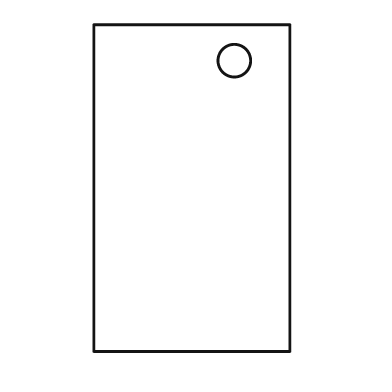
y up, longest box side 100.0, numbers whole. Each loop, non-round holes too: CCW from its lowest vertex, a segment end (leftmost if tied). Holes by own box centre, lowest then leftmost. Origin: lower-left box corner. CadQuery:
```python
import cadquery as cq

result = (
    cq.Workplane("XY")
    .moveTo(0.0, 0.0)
    .lineTo(60.0, 0.0)
    .lineTo(60.0, 100.0)
    .lineTo(0.0, 100.0)
    .close()
    .moveTo(43.0, 89.0)
    .circle(5.0)
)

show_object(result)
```